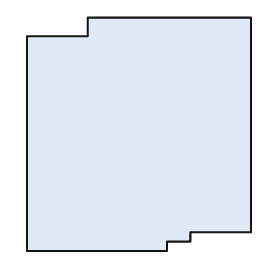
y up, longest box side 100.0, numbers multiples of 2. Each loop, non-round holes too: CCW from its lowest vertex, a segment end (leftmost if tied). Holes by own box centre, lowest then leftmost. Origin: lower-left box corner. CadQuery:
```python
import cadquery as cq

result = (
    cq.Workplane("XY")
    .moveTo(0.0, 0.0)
    .lineTo(60.0, 0.0)
    .lineTo(60.0, 4.0)
    .lineTo(70.0, 4.0)
    .lineTo(70.0, 8.0)
    .lineTo(96.0, 8.0)
    .lineTo(96.0, 100.0)
    .lineTo(26.0, 100.0)
    .lineTo(26.0, 92.0)
    .lineTo(0.0, 92.0)
    .close()
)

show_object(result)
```